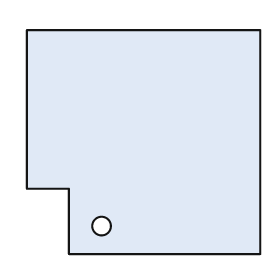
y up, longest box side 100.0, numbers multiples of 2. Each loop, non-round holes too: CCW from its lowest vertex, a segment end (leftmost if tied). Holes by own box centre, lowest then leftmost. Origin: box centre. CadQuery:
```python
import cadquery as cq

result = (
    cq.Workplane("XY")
    .moveTo(-32.0, -48.0)
    .lineTo(50.0, -48.0)
    .lineTo(50.0, 48.0)
    .lineTo(-50.0, 48.0)
    .lineTo(-50.0, -20.0)
    .lineTo(-32.0, -20.0)
    .close()
    .moveTo(-18.0, -36.0)
    .circle(4.0)
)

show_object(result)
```